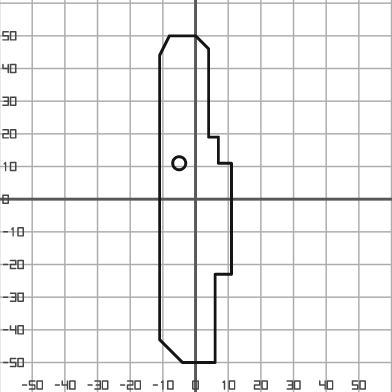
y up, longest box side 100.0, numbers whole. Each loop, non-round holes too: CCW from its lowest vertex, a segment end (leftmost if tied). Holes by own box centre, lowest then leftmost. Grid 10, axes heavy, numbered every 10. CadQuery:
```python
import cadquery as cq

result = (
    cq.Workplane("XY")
    .moveTo(-4.0, -50.0)
    .lineTo(6.0, -50.0)
    .lineTo(6.0, -23.0)
    .lineTo(11.0, -23.0)
    .lineTo(11.0, 11.0)
    .lineTo(7.0, 11.0)
    .lineTo(7.0, 19.0)
    .lineTo(4.0, 19.0)
    .lineTo(4.0, 46.0)
    .lineTo(0.0, 50.0)
    .lineTo(-8.0, 50.0)
    .lineTo(-11.0, 44.0)
    .lineTo(-11.0, -43.0)
    .close()
    .moveTo(-5.0, 11.0)
    .circle(2.0)
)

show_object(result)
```